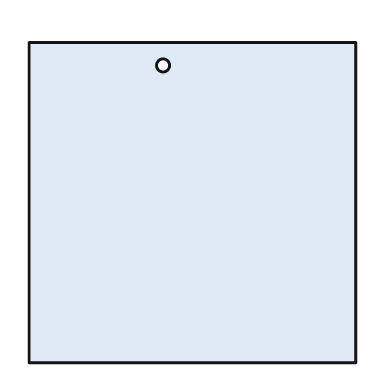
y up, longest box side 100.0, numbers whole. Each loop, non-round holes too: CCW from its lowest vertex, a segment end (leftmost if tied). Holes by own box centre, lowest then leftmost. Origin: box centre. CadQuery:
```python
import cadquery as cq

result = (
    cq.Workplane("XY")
    .moveTo(-50.0, -49.0)
    .lineTo(50.0, -49.0)
    .lineTo(50.0, 49.0)
    .lineTo(-50.0, 49.0)
    .close()
    .moveTo(-9.0, 42.0)
    .circle(2.0)
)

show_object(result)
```